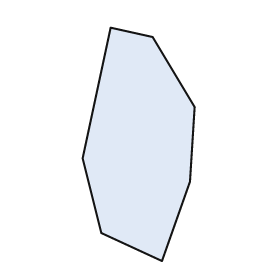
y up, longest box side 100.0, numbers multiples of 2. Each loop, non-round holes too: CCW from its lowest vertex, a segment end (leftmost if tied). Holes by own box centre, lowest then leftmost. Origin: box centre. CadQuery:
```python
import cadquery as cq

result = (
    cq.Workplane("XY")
    .moveTo(10.0, -50.0)
    .lineTo(22.0, -16.0)
    .lineTo(24.0, 16.0)
    .lineTo(6.0, 46.0)
    .lineTo(-12.0, 50.0)
    .lineTo(-24.0, -6.0)
    .lineTo(-16.0, -38.0)
    .close()
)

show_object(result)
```